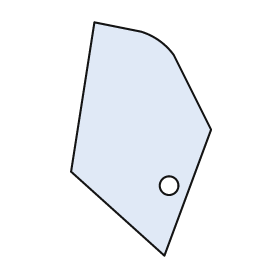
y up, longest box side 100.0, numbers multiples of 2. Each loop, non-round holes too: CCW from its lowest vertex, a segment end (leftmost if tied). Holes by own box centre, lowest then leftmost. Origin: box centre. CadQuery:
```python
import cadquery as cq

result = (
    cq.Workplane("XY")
    .moveTo(10.0, -50.0)
    .lineTo(30.0, 4.0)
    .lineTo(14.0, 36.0)
    .threePointArc((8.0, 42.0), (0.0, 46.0))
    .lineTo(-20.0, 50.0)
    .lineTo(-30.0, -14.0)
    .close()
    .moveTo(12.0, -20.0)
    .circle(4.0)
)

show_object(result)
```